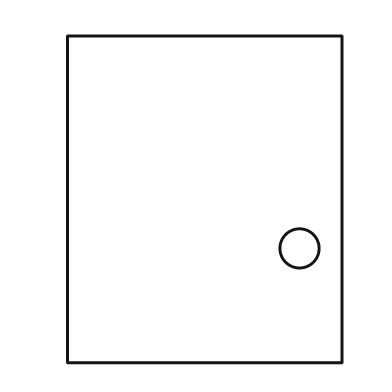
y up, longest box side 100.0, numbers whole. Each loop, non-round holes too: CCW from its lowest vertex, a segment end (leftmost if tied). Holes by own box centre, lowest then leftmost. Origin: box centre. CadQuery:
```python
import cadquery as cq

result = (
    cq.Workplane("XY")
    .moveTo(-42.0, -50.0)
    .lineTo(42.0, -50.0)
    .lineTo(42.0, 50.0)
    .lineTo(-42.0, 50.0)
    .close()
    .moveTo(29.0, -15.0)
    .circle(6.0)
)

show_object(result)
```